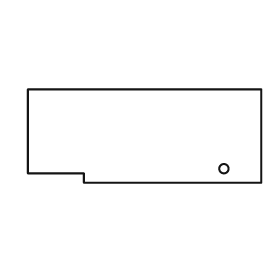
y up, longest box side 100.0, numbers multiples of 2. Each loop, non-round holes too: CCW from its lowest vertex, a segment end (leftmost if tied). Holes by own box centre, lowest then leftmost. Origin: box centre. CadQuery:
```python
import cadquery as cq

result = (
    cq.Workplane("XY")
    .moveTo(-26.0, -20.0)
    .lineTo(50.0, -20.0)
    .lineTo(50.0, 20.0)
    .lineTo(-50.0, 20.0)
    .lineTo(-50.0, -16.0)
    .lineTo(-26.0, -16.0)
    .close()
    .moveTo(34.0, -14.0)
    .circle(2.0)
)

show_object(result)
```